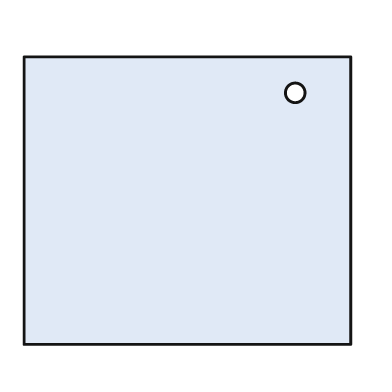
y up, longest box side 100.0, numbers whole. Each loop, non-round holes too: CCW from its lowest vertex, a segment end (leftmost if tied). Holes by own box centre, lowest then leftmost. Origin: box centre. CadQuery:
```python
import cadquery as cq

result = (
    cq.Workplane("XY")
    .moveTo(-50.0, -44.0)
    .lineTo(50.0, -44.0)
    .lineTo(50.0, 44.0)
    .lineTo(-50.0, 44.0)
    .close()
    .moveTo(33.0, 33.0)
    .circle(3.0)
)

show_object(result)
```